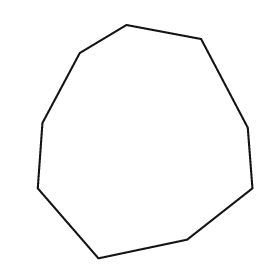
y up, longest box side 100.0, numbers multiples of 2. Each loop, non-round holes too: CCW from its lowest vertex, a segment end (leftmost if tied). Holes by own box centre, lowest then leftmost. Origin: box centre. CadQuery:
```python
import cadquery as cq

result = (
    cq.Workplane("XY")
    .moveTo(-20.0, -50.0)
    .lineTo(18.0, -42.0)
    .lineTo(46.0, -20.0)
    .lineTo(44.0, 6.0)
    .lineTo(24.0, 44.0)
    .lineTo(-8.0, 50.0)
    .lineTo(-28.0, 38.0)
    .lineTo(-44.0, 8.0)
    .lineTo(-46.0, -20.0)
    .close()
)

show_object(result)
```